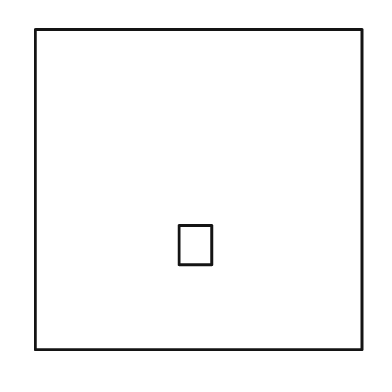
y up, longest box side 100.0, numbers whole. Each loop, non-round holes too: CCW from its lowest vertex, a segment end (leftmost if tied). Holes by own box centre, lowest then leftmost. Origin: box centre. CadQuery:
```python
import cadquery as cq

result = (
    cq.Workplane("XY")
    .moveTo(-50.0, -49.0)
    .lineTo(50.0, -49.0)
    .lineTo(50.0, 49.0)
    .lineTo(-50.0, 49.0)
    .close()
    .moveTo(-6.0, -23.0)
    .lineTo(4.0, -23.0)
    .lineTo(4.0, -11.0)
    .lineTo(-6.0, -11.0)
    .close()
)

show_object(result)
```